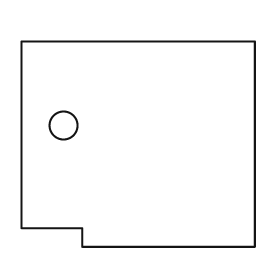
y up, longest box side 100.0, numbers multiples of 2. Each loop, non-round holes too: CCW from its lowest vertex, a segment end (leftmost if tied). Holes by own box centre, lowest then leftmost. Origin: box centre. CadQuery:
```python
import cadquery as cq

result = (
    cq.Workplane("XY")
    .moveTo(-24.0, -44.0)
    .lineTo(50.0, -44.0)
    .lineTo(50.0, 44.0)
    .lineTo(-50.0, 44.0)
    .lineTo(-50.0, -36.0)
    .lineTo(-24.0, -36.0)
    .close()
    .moveTo(-32.0, 8.0)
    .circle(6.0)
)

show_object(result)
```